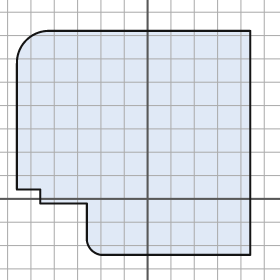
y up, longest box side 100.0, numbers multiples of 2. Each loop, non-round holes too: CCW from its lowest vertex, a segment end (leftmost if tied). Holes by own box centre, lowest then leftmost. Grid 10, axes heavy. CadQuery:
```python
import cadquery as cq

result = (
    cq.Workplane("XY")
    .moveTo(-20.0, -24.0)
    .lineTo(44.0, -24.0)
    .lineTo(44.0, 72.0)
    .lineTo(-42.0, 72.0)
    .threePointArc((-52.0, 68.0), (-56.0, 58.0))
    .lineTo(-56.0, 4.0)
    .lineTo(-46.0, 4.0)
    .lineTo(-46.0, -2.0)
    .lineTo(-26.0, -2.0)
    .lineTo(-26.0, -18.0)
    .threePointArc((-24.0, -22.0), (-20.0, -24.0))
    .close()
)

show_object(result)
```